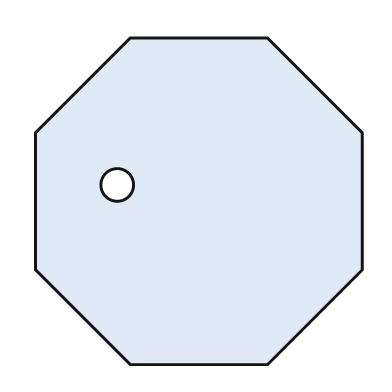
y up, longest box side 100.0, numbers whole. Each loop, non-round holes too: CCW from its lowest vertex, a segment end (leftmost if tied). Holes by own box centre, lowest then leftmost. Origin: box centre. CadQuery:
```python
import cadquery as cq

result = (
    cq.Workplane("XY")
    .moveTo(-21.0, -50.0)
    .lineTo(21.0, -50.0)
    .lineTo(50.0, -21.0)
    .lineTo(50.0, 21.0)
    .lineTo(21.0, 50.0)
    .lineTo(-21.0, 50.0)
    .lineTo(-50.0, 21.0)
    .lineTo(-50.0, -21.0)
    .close()
    .moveTo(-25.0, 5.0)
    .circle(5.0)
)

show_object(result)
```